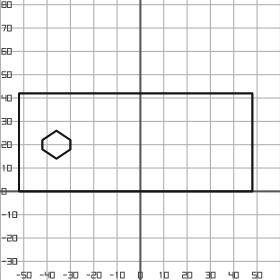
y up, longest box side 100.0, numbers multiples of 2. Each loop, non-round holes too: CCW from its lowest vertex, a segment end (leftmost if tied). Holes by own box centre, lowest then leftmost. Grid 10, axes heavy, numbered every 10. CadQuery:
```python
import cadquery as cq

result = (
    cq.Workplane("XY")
    .moveTo(-52.0, 0.0)
    .lineTo(48.0, 0.0)
    .lineTo(48.0, 42.0)
    .lineTo(-52.0, 42.0)
    .close()
    .moveTo(-36.0, 14.0)
    .lineTo(-30.0, 18.0)
    .lineTo(-30.0, 22.0)
    .lineTo(-36.0, 26.0)
    .lineTo(-42.0, 22.0)
    .lineTo(-42.0, 18.0)
    .close()
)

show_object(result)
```